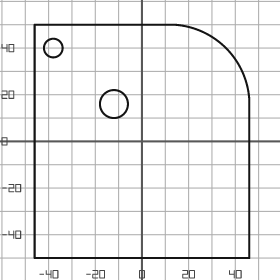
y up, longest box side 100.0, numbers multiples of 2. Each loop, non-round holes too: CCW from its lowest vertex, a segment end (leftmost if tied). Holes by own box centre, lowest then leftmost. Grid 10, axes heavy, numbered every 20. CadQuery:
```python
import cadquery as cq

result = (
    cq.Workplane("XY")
    .moveTo(-46.0, -50.0)
    .lineTo(46.0, -50.0)
    .lineTo(46.0, 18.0)
    .threePointArc((36.0, 40.0), (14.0, 50.0))
    .lineTo(-46.0, 50.0)
    .close()
    .moveTo(-12.0, 16.0)
    .circle(6.0)
    .moveTo(-38.0, 40.0)
    .circle(4.0)
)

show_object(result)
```